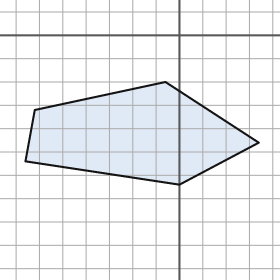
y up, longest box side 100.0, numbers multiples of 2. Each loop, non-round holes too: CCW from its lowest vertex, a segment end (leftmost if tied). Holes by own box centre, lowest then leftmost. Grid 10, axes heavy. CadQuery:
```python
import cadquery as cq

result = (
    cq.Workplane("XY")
    .moveTo(0.0, -64.0)
    .lineTo(34.0, -46.0)
    .lineTo(-6.0, -20.0)
    .lineTo(-62.0, -32.0)
    .lineTo(-66.0, -54.0)
    .close()
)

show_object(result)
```